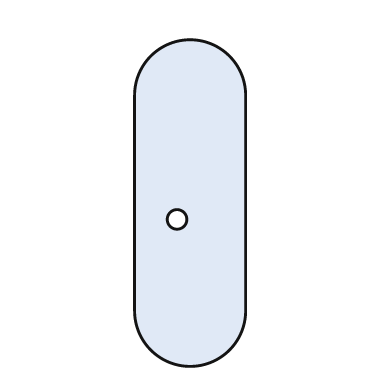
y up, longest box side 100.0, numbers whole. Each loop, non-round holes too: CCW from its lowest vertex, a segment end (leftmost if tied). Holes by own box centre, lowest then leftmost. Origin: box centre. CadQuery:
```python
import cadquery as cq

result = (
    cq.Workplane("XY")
    .moveTo(-17.0, -33.0)
    .threePointArc((0.0, -50.0), (17.0, -33.0))
    .lineTo(17.0, 33.0)
    .threePointArc((0.0, 50.0), (-17.0, 33.0))
    .close()
    .moveTo(-4.0, -5.0)
    .circle(3.0)
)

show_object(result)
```